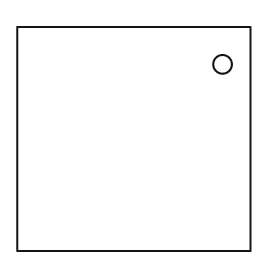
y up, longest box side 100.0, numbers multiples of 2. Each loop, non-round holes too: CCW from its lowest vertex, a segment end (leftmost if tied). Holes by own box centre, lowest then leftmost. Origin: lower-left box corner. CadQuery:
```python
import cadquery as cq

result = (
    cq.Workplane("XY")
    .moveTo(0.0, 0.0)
    .lineTo(100.0, 0.0)
    .lineTo(100.0, 96.0)
    .lineTo(0.0, 96.0)
    .close()
    .moveTo(88.0, 80.0)
    .circle(4.0)
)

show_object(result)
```